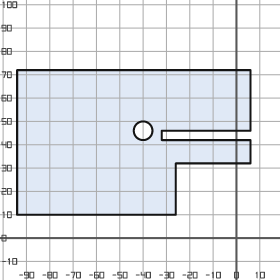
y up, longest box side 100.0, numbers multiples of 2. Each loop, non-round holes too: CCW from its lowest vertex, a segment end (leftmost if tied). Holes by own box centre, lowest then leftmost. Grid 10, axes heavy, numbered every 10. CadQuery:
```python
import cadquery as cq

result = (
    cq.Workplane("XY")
    .moveTo(-94.0, 10.0)
    .lineTo(-26.0, 10.0)
    .lineTo(-26.0, 32.0)
    .lineTo(6.0, 32.0)
    .lineTo(6.0, 42.0)
    .lineTo(-32.0, 42.0)
    .lineTo(-32.0, 46.0)
    .lineTo(6.0, 46.0)
    .lineTo(6.0, 72.0)
    .lineTo(-94.0, 72.0)
    .close()
    .moveTo(-40.0, 46.0)
    .circle(4.0)
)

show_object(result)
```